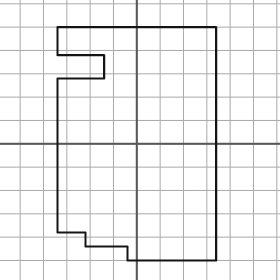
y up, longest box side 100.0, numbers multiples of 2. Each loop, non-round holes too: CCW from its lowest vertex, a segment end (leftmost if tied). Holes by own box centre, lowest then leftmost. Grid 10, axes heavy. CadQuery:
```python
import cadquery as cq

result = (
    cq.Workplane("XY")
    .moveTo(-4.0, -50.0)
    .lineTo(34.0, -50.0)
    .lineTo(34.0, 50.0)
    .lineTo(-34.0, 50.0)
    .lineTo(-34.0, 38.0)
    .lineTo(-14.0, 38.0)
    .lineTo(-14.0, 28.0)
    .lineTo(-34.0, 28.0)
    .lineTo(-34.0, -38.0)
    .lineTo(-22.0, -38.0)
    .lineTo(-22.0, -44.0)
    .lineTo(-4.0, -44.0)
    .close()
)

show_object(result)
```